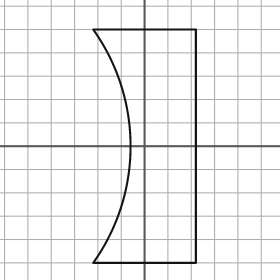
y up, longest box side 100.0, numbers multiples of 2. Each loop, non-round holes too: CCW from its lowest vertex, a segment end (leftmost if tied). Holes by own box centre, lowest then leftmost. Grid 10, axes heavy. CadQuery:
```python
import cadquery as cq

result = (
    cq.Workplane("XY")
    .moveTo(-22.0, -50.0)
    .lineTo(22.0, -50.0)
    .lineTo(22.0, 50.0)
    .lineTo(-22.0, 50.0)
    .threePointArc((-6.0, 0.0), (-22.0, -50.0))
    .close()
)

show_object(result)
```